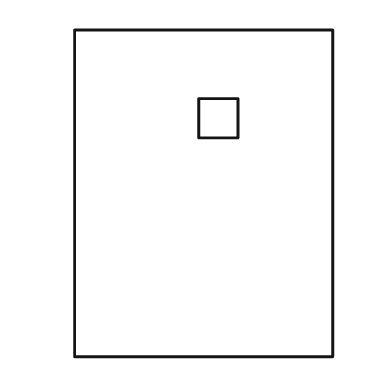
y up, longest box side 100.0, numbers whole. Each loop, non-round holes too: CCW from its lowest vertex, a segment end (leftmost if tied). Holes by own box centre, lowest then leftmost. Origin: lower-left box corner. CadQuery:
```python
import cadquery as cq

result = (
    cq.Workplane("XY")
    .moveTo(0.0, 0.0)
    .lineTo(79.0, 0.0)
    .lineTo(79.0, 100.0)
    .lineTo(0.0, 100.0)
    .close()
    .moveTo(38.0, 67.0)
    .lineTo(50.0, 67.0)
    .lineTo(50.0, 79.0)
    .lineTo(38.0, 79.0)
    .close()
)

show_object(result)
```